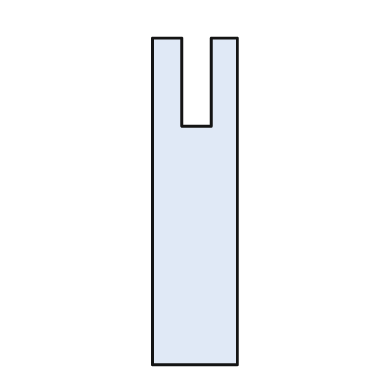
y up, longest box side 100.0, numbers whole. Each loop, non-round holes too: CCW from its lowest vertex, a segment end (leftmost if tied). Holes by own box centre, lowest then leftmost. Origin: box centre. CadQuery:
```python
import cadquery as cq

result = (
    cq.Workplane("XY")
    .moveTo(-13.0, -50.0)
    .lineTo(13.0, -50.0)
    .lineTo(13.0, 50.0)
    .lineTo(5.0, 50.0)
    .lineTo(5.0, 23.0)
    .lineTo(-4.0, 23.0)
    .lineTo(-4.0, 50.0)
    .lineTo(-13.0, 50.0)
    .close()
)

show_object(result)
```